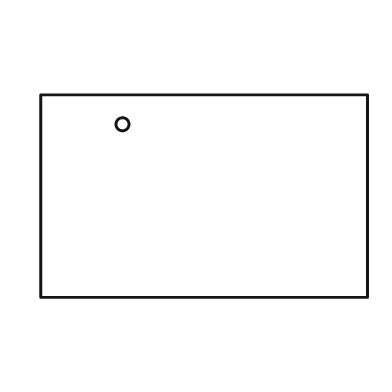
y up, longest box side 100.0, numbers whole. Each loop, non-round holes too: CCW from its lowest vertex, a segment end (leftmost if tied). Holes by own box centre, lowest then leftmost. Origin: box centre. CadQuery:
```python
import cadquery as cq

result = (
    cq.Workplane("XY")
    .moveTo(-50.0, -31.0)
    .lineTo(50.0, -31.0)
    .lineTo(50.0, 31.0)
    .lineTo(-50.0, 31.0)
    .close()
    .moveTo(-25.0, 22.0)
    .circle(2.0)
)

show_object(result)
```